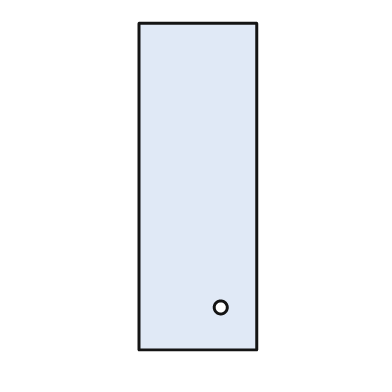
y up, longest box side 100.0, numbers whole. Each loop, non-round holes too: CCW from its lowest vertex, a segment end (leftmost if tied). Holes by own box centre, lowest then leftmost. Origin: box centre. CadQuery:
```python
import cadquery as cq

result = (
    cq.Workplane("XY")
    .moveTo(-18.0, -50.0)
    .lineTo(18.0, -50.0)
    .lineTo(18.0, 50.0)
    .lineTo(-18.0, 50.0)
    .close()
    .moveTo(7.0, -37.0)
    .circle(2.0)
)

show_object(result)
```